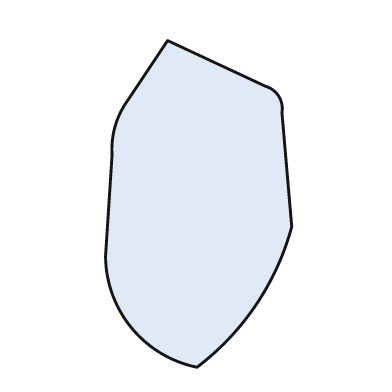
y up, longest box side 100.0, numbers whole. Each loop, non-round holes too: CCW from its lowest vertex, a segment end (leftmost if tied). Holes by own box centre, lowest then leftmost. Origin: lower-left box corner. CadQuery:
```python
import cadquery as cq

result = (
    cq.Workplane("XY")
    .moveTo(28.0, 0.0)
    .threePointArc((46.0, 19.0), (57.0, 43.0))
    .lineTo(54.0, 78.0)
    .threePointArc((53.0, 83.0), (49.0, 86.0))
    .lineTo(19.0, 100.0)
    .lineTo(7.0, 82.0)
    .threePointArc((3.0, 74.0), (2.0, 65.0))
    .lineTo(0.0, 34.0)
    .threePointArc((8.0, 12.0), (28.0, 0.0))
    .close()
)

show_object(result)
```